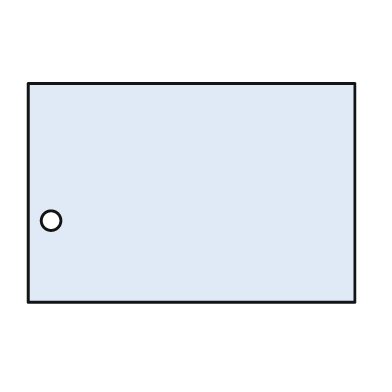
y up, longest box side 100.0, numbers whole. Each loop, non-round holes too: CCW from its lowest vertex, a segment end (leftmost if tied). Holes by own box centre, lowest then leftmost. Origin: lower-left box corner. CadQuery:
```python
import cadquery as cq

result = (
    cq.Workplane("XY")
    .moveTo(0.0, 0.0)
    .lineTo(100.0, 0.0)
    .lineTo(100.0, 67.0)
    .lineTo(0.0, 67.0)
    .close()
    .moveTo(7.0, 25.0)
    .circle(3.0)
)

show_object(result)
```